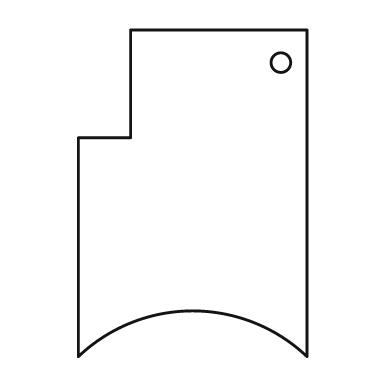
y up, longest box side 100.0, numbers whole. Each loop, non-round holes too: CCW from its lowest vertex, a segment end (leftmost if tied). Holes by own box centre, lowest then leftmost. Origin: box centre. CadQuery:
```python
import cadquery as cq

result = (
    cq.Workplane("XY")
    .moveTo(-35.0, -50.0)
    .threePointArc((0.0, -36.0), (35.0, -50.0))
    .lineTo(35.0, 50.0)
    .lineTo(-19.0, 50.0)
    .lineTo(-19.0, 17.0)
    .lineTo(-35.0, 17.0)
    .close()
    .moveTo(27.0, 40.0)
    .circle(3.0)
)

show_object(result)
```